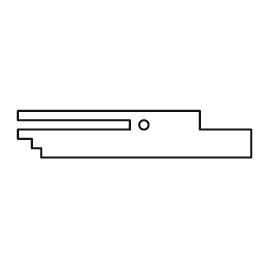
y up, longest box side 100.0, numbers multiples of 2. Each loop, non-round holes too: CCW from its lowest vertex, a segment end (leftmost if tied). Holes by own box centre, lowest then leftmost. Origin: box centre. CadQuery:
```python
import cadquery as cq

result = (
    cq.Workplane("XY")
    .moveTo(-40.0, -10.0)
    .lineTo(50.0, -10.0)
    .lineTo(50.0, 2.0)
    .lineTo(28.0, 2.0)
    .lineTo(28.0, 10.0)
    .lineTo(-50.0, 10.0)
    .lineTo(-50.0, 6.0)
    .lineTo(-2.0, 6.0)
    .lineTo(-2.0, 2.0)
    .lineTo(-50.0, 2.0)
    .lineTo(-50.0, -2.0)
    .lineTo(-44.0, -2.0)
    .lineTo(-44.0, -6.0)
    .lineTo(-40.0, -6.0)
    .close()
    .moveTo(4.0, 4.0)
    .circle(2.0)
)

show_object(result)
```